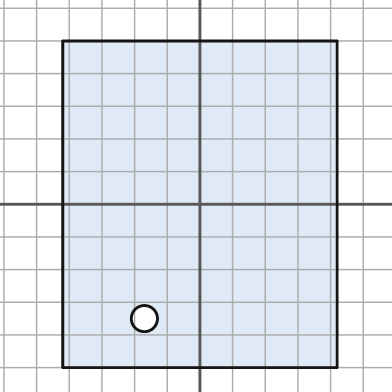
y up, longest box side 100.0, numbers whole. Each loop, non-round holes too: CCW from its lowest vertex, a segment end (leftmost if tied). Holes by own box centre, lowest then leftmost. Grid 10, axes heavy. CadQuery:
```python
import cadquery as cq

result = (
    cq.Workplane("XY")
    .moveTo(-42.0, -50.0)
    .lineTo(42.0, -50.0)
    .lineTo(42.0, 50.0)
    .lineTo(-42.0, 50.0)
    .close()
    .moveTo(-17.0, -35.0)
    .circle(4.0)
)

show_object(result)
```